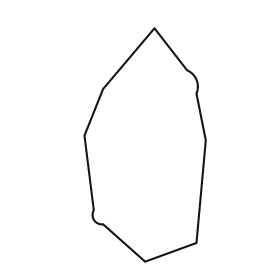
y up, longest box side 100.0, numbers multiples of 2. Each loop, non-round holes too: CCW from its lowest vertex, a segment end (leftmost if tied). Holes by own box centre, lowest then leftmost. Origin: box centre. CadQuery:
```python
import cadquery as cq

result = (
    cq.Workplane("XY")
    .moveTo(0.0, -50.0)
    .lineTo(22.0, -42.0)
    .lineTo(26.0, 2.0)
    .lineTo(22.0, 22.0)
    .threePointArc((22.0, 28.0), (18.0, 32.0))
    .lineTo(4.0, 50.0)
    .lineTo(-18.0, 24.0)
    .lineTo(-26.0, 4.0)
    .lineTo(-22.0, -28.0)
    .threePointArc((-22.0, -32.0), (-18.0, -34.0))
    .close()
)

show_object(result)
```